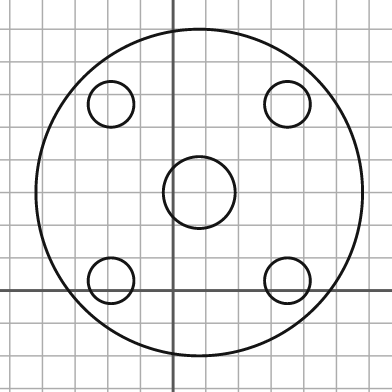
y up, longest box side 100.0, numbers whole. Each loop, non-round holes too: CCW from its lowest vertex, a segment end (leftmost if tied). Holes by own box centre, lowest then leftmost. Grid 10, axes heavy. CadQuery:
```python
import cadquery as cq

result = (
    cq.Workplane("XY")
    .moveTo(8.0, 30.0)
    .circle(50.0)
    .moveTo(-19.0, 3.0)
    .circle(7.0)
    .moveTo(35.0, 3.0)
    .circle(7.0)
    .moveTo(8.0, 30.0)
    .circle(11.0)
    .moveTo(-19.0, 57.0)
    .circle(7.0)
    .moveTo(35.0, 57.0)
    .circle(7.0)
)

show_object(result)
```